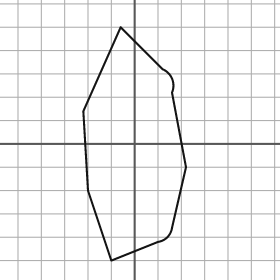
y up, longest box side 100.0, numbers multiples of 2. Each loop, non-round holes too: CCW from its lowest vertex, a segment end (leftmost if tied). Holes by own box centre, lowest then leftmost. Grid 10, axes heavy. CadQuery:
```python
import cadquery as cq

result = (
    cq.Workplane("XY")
    .moveTo(-10.0, -50.0)
    .lineTo(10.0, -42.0)
    .threePointArc((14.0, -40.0), (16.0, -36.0))
    .lineTo(22.0, -10.0)
    .lineTo(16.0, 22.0)
    .threePointArc((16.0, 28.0), (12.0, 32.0))
    .lineTo(-6.0, 50.0)
    .lineTo(-22.0, 14.0)
    .lineTo(-20.0, -20.0)
    .close()
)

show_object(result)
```